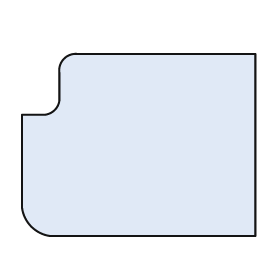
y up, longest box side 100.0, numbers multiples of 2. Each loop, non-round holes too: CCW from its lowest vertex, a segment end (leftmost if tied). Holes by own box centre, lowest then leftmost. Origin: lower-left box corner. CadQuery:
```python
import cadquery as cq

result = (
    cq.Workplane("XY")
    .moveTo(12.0, 0.0)
    .lineTo(100.0, 0.0)
    .lineTo(100.0, 78.0)
    .lineTo(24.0, 78.0)
    .threePointArc((18.0, 76.0), (16.0, 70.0))
    .lineTo(16.0, 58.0)
    .threePointArc((14.0, 54.0), (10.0, 52.0))
    .lineTo(0.0, 52.0)
    .lineTo(0.0, 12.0)
    .threePointArc((4.0, 4.0), (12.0, 0.0))
    .close()
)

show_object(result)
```